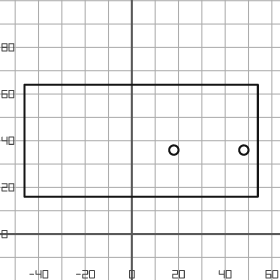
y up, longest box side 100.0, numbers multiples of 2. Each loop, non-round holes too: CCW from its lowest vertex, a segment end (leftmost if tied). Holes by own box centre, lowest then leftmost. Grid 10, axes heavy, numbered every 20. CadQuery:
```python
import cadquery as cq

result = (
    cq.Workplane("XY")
    .moveTo(-46.0, 16.0)
    .lineTo(54.0, 16.0)
    .lineTo(54.0, 64.0)
    .lineTo(-46.0, 64.0)
    .close()
    .moveTo(18.0, 36.0)
    .circle(2.0)
    .moveTo(48.0, 36.0)
    .circle(2.0)
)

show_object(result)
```